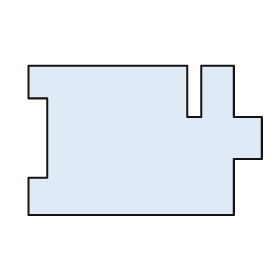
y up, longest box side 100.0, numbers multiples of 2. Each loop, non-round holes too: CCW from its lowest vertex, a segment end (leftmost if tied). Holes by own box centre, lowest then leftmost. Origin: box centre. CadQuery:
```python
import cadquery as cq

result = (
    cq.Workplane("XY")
    .moveTo(-50.0, -32.0)
    .lineTo(38.0, -32.0)
    .lineTo(38.0, -8.0)
    .lineTo(50.0, -8.0)
    .lineTo(50.0, 10.0)
    .lineTo(38.0, 10.0)
    .lineTo(38.0, 32.0)
    .lineTo(24.0, 32.0)
    .lineTo(24.0, 10.0)
    .lineTo(18.0, 10.0)
    .lineTo(18.0, 32.0)
    .lineTo(-50.0, 32.0)
    .lineTo(-50.0, 18.0)
    .lineTo(-42.0, 18.0)
    .lineTo(-42.0, -16.0)
    .lineTo(-50.0, -16.0)
    .close()
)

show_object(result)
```